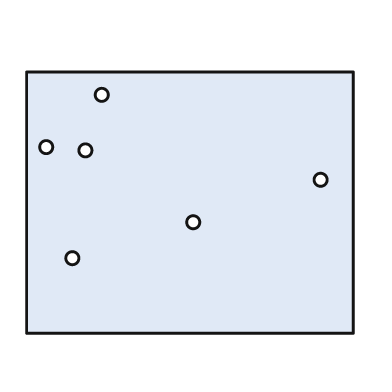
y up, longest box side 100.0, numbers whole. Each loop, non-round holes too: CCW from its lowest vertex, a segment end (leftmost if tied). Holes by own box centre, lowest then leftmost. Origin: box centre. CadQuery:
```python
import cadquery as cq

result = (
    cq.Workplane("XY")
    .moveTo(-50.0, -40.0)
    .lineTo(50.0, -40.0)
    .lineTo(50.0, 40.0)
    .lineTo(-50.0, 40.0)
    .close()
    .moveTo(-36.0, -17.0)
    .circle(2.0)
    .moveTo(1.0, -6.0)
    .circle(2.0)
    .moveTo(40.0, 7.0)
    .circle(2.0)
    .moveTo(-32.0, 16.0)
    .circle(2.0)
    .moveTo(-44.0, 17.0)
    .circle(2.0)
    .moveTo(-27.0, 33.0)
    .circle(2.0)
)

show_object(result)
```